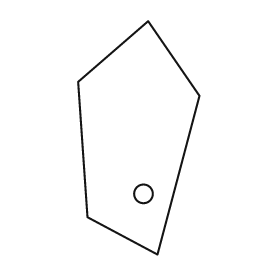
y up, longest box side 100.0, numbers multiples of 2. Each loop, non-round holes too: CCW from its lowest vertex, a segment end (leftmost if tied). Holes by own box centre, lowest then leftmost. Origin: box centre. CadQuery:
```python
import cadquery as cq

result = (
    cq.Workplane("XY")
    .moveTo(8.0, -50.0)
    .lineTo(26.0, 18.0)
    .lineTo(4.0, 50.0)
    .lineTo(-26.0, 24.0)
    .lineTo(-22.0, -34.0)
    .close()
    .moveTo(2.0, -24.0)
    .circle(4.0)
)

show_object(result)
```